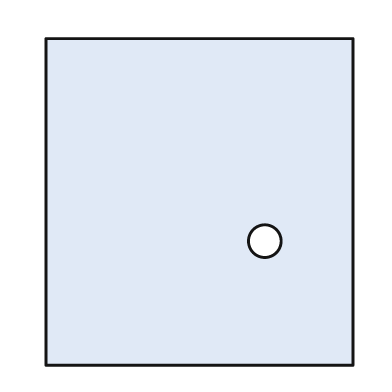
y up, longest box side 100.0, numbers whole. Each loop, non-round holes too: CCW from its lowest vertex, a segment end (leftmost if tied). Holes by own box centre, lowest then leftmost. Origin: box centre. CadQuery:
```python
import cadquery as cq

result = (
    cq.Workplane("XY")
    .moveTo(-47.0, -50.0)
    .lineTo(47.0, -50.0)
    .lineTo(47.0, 50.0)
    .lineTo(-47.0, 50.0)
    .close()
    .moveTo(20.0, -12.0)
    .circle(5.0)
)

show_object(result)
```